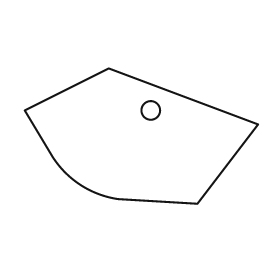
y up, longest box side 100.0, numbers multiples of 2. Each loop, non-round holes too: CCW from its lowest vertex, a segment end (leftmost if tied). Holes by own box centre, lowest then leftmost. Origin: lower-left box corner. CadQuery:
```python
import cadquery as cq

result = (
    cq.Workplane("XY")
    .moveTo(74.0, 0.0)
    .lineTo(100.0, 34.0)
    .lineTo(36.0, 58.0)
    .lineTo(0.0, 40.0)
    .lineTo(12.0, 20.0)
    .threePointArc((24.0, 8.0), (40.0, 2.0))
    .close()
    .moveTo(54.0, 40.0)
    .circle(4.0)
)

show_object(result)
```